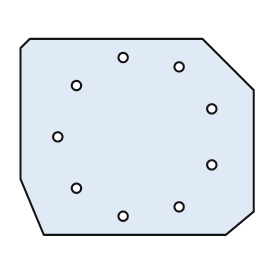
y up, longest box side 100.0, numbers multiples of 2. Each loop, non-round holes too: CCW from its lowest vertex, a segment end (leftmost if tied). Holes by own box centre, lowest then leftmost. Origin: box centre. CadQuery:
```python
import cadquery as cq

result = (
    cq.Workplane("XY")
    .moveTo(-40.0, -42.0)
    .lineTo(38.0, -42.0)
    .lineTo(50.0, -32.0)
    .lineTo(50.0, 20.0)
    .lineTo(28.0, 42.0)
    .lineTo(-46.0, 42.0)
    .lineTo(-50.0, 38.0)
    .lineTo(-50.0, -18.0)
    .close()
    .moveTo(-6.0, -34.0)
    .circle(2.0)
    .moveTo(18.0, -30.0)
    .circle(2.0)
    .moveTo(-26.0, -22.0)
    .circle(2.0)
    .moveTo(32.0, -12.0)
    .circle(2.0)
    .moveTo(-34.0, 0.0)
    .circle(2.0)
    .moveTo(32.0, 12.0)
    .circle(2.0)
    .moveTo(-26.0, 22.0)
    .circle(2.0)
    .moveTo(18.0, 30.0)
    .circle(2.0)
    .moveTo(-6.0, 34.0)
    .circle(2.0)
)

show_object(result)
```